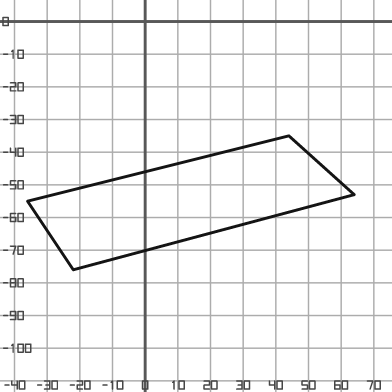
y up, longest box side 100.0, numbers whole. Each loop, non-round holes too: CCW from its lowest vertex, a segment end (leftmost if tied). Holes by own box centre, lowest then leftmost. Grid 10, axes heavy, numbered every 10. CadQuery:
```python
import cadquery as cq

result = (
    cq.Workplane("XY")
    .moveTo(-22.0, -76.0)
    .lineTo(64.0, -53.0)
    .lineTo(44.0, -35.0)
    .lineTo(-36.0, -55.0)
    .close()
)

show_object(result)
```